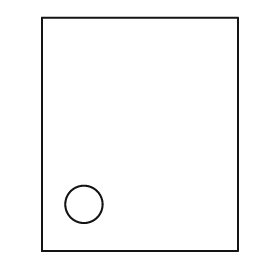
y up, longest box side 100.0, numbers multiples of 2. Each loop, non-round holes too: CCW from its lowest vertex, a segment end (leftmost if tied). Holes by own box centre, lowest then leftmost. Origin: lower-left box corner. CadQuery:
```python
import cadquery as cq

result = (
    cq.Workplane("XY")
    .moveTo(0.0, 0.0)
    .lineTo(84.0, 0.0)
    .lineTo(84.0, 100.0)
    .lineTo(0.0, 100.0)
    .close()
    .moveTo(18.0, 20.0)
    .circle(8.0)
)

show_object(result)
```